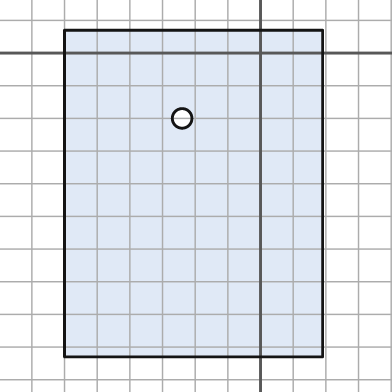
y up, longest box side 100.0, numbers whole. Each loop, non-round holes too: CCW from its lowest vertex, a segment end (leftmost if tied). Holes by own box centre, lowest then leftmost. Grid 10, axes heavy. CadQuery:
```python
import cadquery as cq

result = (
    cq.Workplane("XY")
    .moveTo(-60.0, -93.0)
    .lineTo(19.0, -93.0)
    .lineTo(19.0, 7.0)
    .lineTo(-60.0, 7.0)
    .close()
    .moveTo(-24.0, -20.0)
    .circle(3.0)
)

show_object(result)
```